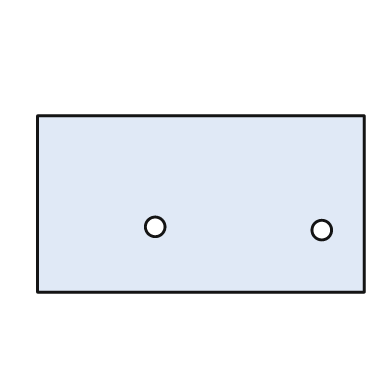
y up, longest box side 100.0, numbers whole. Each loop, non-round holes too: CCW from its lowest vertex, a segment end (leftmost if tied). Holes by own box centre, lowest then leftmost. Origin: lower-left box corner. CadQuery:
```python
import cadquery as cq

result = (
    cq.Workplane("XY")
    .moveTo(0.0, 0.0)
    .lineTo(100.0, 0.0)
    .lineTo(100.0, 54.0)
    .lineTo(0.0, 54.0)
    .close()
    .moveTo(87.0, 19.0)
    .circle(3.0)
    .moveTo(36.0, 20.0)
    .circle(3.0)
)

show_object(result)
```